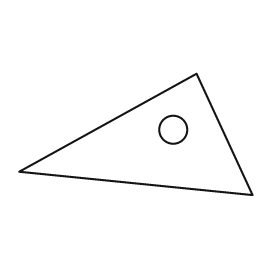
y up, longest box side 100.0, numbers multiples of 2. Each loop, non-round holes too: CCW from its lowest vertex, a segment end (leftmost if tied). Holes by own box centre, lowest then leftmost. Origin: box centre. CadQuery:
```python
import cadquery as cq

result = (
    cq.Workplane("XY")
    .moveTo(50.0, -26.0)
    .lineTo(26.0, 26.0)
    .lineTo(-50.0, -16.0)
    .close()
    .moveTo(16.0, 2.0)
    .circle(6.0)
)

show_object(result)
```